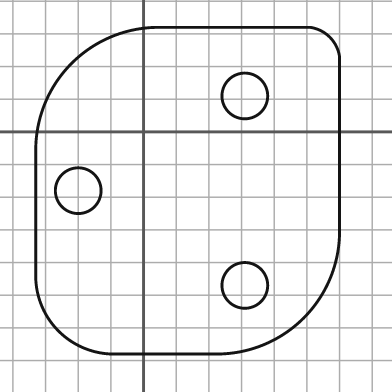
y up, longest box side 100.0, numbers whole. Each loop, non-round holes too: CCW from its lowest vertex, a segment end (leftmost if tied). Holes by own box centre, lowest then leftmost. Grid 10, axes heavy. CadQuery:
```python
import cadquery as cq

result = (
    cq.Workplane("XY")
    .moveTo(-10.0, -68.0)
    .lineTo(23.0, -68.0)
    .threePointArc((49.0, -57.0), (60.0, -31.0))
    .lineTo(60.0, 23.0)
    .threePointArc((57.0, 29.0), (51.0, 32.0))
    .lineTo(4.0, 32.0)
    .threePointArc((-22.0, 21.0), (-33.0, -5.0))
    .lineTo(-33.0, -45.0)
    .threePointArc((-26.0, -61.0), (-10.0, -68.0))
    .close()
    .moveTo(31.0, -47.0)
    .circle(7.0)
    .moveTo(-20.0, -18.0)
    .circle(7.0)
    .moveTo(31.0, 11.0)
    .circle(7.0)
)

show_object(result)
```